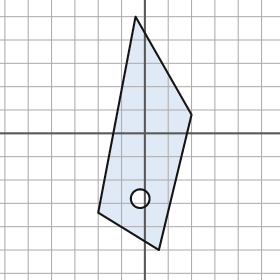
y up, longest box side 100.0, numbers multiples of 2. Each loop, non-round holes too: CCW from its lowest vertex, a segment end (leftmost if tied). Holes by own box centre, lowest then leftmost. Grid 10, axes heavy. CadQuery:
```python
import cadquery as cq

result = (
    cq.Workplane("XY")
    .moveTo(6.0, -50.0)
    .lineTo(20.0, 8.0)
    .lineTo(-4.0, 50.0)
    .lineTo(-20.0, -34.0)
    .close()
    .moveTo(-2.0, -28.0)
    .circle(4.0)
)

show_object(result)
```